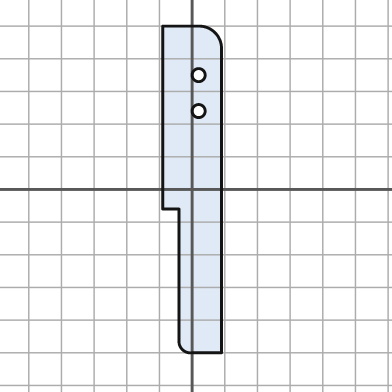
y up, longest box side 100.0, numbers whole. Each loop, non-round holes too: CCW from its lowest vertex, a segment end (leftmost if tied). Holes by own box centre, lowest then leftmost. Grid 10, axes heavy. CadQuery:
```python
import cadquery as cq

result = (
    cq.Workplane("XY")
    .moveTo(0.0, -50.0)
    .lineTo(9.0, -50.0)
    .lineTo(9.0, 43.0)
    .threePointArc((7.0, 48.0), (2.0, 50.0))
    .lineTo(-9.0, 50.0)
    .lineTo(-9.0, -6.0)
    .lineTo(-4.0, -6.0)
    .lineTo(-4.0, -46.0)
    .threePointArc((-3.0, -49.0), (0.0, -50.0))
    .close()
    .moveTo(2.0, 24.0)
    .circle(2.0)
    .moveTo(2.0, 35.0)
    .circle(2.0)
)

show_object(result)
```